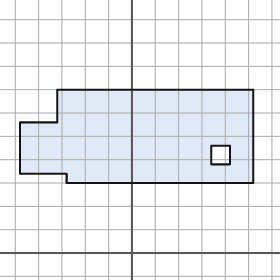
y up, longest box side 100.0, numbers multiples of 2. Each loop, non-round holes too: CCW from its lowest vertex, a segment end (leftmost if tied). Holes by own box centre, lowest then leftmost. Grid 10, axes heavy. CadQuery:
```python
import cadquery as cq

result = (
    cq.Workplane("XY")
    .moveTo(-28.0, 30.0)
    .lineTo(52.0, 30.0)
    .lineTo(52.0, 70.0)
    .lineTo(-32.0, 70.0)
    .lineTo(-32.0, 56.0)
    .lineTo(-48.0, 56.0)
    .lineTo(-48.0, 34.0)
    .lineTo(-28.0, 34.0)
    .close()
    .moveTo(34.0, 38.0)
    .lineTo(42.0, 38.0)
    .lineTo(42.0, 46.0)
    .lineTo(34.0, 46.0)
    .close()
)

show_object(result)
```